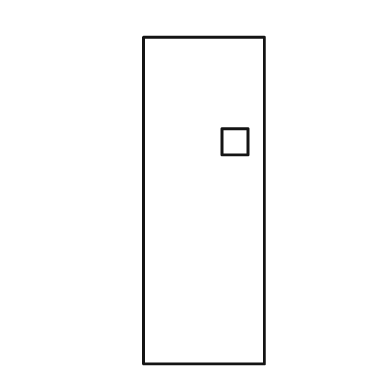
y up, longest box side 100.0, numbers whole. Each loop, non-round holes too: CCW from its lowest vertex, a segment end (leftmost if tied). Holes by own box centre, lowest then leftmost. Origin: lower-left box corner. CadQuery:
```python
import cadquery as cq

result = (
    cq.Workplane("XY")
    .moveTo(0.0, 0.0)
    .lineTo(37.0, 0.0)
    .lineTo(37.0, 100.0)
    .lineTo(0.0, 100.0)
    .close()
    .moveTo(24.0, 64.0)
    .lineTo(32.0, 64.0)
    .lineTo(32.0, 72.0)
    .lineTo(24.0, 72.0)
    .close()
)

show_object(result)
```